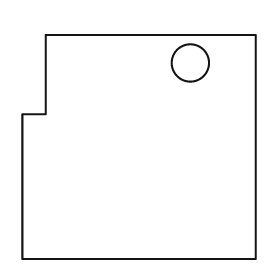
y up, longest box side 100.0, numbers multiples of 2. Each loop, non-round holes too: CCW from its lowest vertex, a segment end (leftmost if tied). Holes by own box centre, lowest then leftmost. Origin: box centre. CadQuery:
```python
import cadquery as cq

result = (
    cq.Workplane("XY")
    .moveTo(-50.0, -48.0)
    .lineTo(50.0, -48.0)
    .lineTo(50.0, 48.0)
    .lineTo(-40.0, 48.0)
    .lineTo(-40.0, 14.0)
    .lineTo(-50.0, 14.0)
    .close()
    .moveTo(22.0, 36.0)
    .circle(8.0)
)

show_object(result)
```